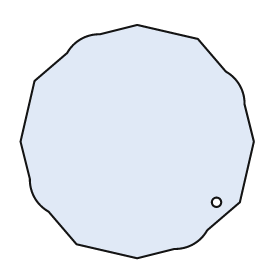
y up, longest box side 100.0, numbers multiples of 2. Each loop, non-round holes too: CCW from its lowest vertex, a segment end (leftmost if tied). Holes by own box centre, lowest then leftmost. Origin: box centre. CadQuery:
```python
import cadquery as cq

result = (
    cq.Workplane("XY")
    .moveTo(0.0, -50.0)
    .lineTo(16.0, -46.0)
    .threePointArc((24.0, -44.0), (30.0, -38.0))
    .lineTo(44.0, -26.0)
    .lineTo(50.0, 0.0)
    .lineTo(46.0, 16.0)
    .threePointArc((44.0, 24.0), (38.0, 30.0))
    .lineTo(26.0, 44.0)
    .lineTo(0.0, 50.0)
    .lineTo(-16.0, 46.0)
    .threePointArc((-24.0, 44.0), (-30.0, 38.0))
    .lineTo(-44.0, 26.0)
    .lineTo(-50.0, 0.0)
    .lineTo(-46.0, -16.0)
    .threePointArc((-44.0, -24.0), (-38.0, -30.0))
    .lineTo(-26.0, -44.0)
    .close()
    .moveTo(34.0, -26.0)
    .circle(2.0)
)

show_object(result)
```